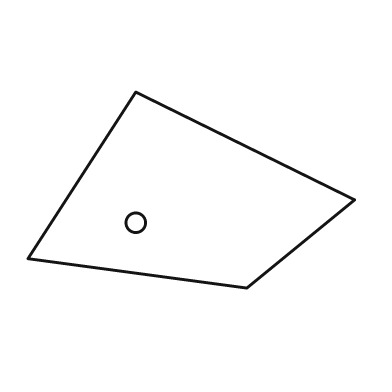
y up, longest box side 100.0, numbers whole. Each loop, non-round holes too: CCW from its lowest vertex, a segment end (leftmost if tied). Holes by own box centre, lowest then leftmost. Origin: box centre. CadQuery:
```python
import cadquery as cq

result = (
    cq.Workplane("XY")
    .moveTo(17.0, -30.0)
    .lineTo(50.0, -3.0)
    .lineTo(-17.0, 30.0)
    .lineTo(-50.0, -21.0)
    .close()
    .moveTo(-17.0, -10.0)
    .circle(3.0)
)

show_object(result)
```